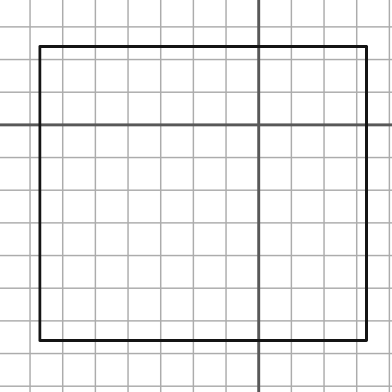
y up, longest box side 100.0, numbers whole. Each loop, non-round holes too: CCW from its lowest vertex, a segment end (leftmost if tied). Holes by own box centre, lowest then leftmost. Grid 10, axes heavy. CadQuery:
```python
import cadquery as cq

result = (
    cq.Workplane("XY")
    .moveTo(-67.0, -66.0)
    .lineTo(33.0, -66.0)
    .lineTo(33.0, 24.0)
    .lineTo(-67.0, 24.0)
    .close()
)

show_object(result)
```